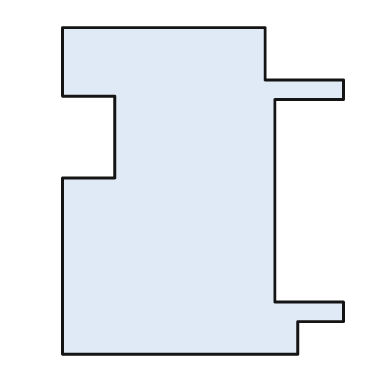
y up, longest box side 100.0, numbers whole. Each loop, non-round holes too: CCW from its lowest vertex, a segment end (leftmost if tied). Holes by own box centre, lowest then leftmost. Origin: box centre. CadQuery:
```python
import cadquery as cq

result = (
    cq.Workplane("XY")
    .moveTo(-43.0, -50.0)
    .lineTo(29.0, -50.0)
    .lineTo(29.0, -40.0)
    .lineTo(43.0, -40.0)
    .lineTo(43.0, -34.0)
    .lineTo(22.0, -34.0)
    .lineTo(22.0, 28.0)
    .lineTo(43.0, 28.0)
    .lineTo(43.0, 34.0)
    .lineTo(19.0, 34.0)
    .lineTo(19.0, 50.0)
    .lineTo(-43.0, 50.0)
    .lineTo(-43.0, 29.0)
    .lineTo(-27.0, 29.0)
    .lineTo(-27.0, 4.0)
    .lineTo(-43.0, 4.0)
    .close()
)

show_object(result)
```